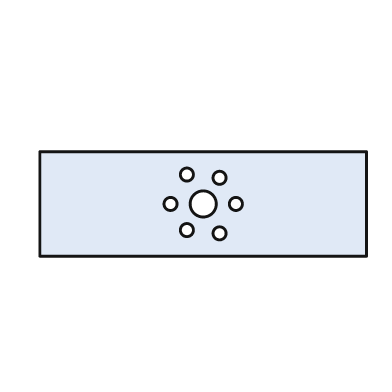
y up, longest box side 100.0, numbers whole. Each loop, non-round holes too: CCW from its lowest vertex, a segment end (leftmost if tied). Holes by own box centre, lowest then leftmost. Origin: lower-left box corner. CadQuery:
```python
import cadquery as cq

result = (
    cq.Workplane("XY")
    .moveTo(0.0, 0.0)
    .lineTo(100.0, 0.0)
    .lineTo(100.0, 32.0)
    .lineTo(0.0, 32.0)
    .close()
    .moveTo(55.0, 7.0)
    .circle(2.0)
    .moveTo(45.0, 8.0)
    .circle(2.0)
    .moveTo(40.0, 16.0)
    .circle(2.0)
    .moveTo(50.0, 16.0)
    .circle(4.0)
    .moveTo(60.0, 16.0)
    .circle(2.0)
    .moveTo(55.0, 24.0)
    .circle(2.0)
    .moveTo(45.0, 25.0)
    .circle(2.0)
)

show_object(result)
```